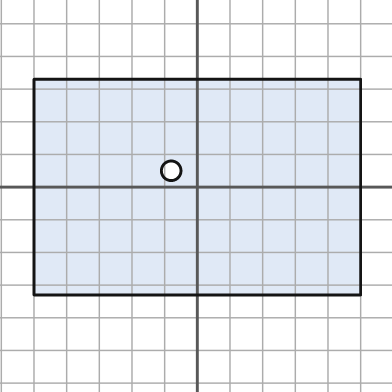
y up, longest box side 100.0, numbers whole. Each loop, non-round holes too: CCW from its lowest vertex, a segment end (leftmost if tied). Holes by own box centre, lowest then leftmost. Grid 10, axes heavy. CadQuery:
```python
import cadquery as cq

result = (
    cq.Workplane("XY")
    .moveTo(-50.0, -33.0)
    .lineTo(50.0, -33.0)
    .lineTo(50.0, 33.0)
    .lineTo(-50.0, 33.0)
    .close()
    .moveTo(-8.0, 5.0)
    .circle(3.0)
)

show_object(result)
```